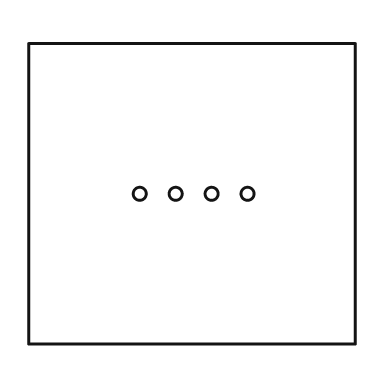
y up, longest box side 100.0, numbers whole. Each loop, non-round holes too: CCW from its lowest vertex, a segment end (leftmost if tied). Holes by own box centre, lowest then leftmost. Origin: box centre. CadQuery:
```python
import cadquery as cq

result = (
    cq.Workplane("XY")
    .moveTo(-50.0, -46.0)
    .lineTo(50.0, -46.0)
    .lineTo(50.0, 46.0)
    .lineTo(-50.0, 46.0)
    .close()
    .moveTo(-16.0, 0.0)
    .circle(2.0)
    .moveTo(-5.0, 0.0)
    .circle(2.0)
    .moveTo(6.0, 0.0)
    .circle(2.0)
    .moveTo(17.0, 0.0)
    .circle(2.0)
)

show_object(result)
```